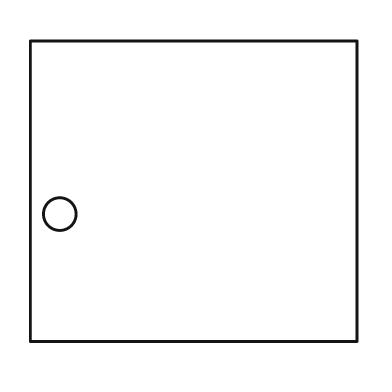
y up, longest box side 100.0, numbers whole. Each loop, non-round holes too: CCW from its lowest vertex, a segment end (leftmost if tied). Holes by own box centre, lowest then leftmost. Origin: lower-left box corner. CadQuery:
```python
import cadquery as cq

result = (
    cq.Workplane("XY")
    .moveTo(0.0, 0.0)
    .lineTo(100.0, 0.0)
    .lineTo(100.0, 92.0)
    .lineTo(0.0, 92.0)
    .close()
    .moveTo(9.0, 39.0)
    .circle(5.0)
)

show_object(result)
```